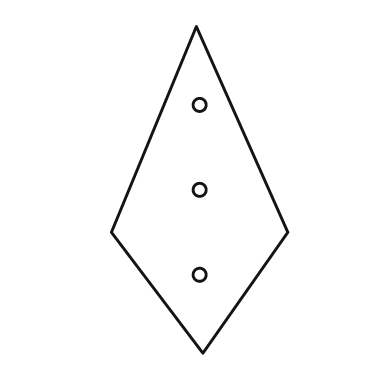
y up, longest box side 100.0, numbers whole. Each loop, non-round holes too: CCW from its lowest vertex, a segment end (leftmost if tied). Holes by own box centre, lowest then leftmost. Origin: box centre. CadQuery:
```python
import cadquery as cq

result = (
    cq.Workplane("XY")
    .moveTo(1.0, -50.0)
    .lineTo(27.0, -13.0)
    .lineTo(-1.0, 50.0)
    .lineTo(-27.0, -13.0)
    .close()
    .moveTo(0.0, -26.0)
    .circle(2.0)
    .moveTo(0.0, 0.0)
    .circle(2.0)
    .moveTo(0.0, 26.0)
    .circle(2.0)
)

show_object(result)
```